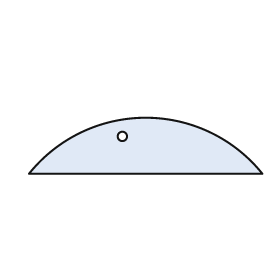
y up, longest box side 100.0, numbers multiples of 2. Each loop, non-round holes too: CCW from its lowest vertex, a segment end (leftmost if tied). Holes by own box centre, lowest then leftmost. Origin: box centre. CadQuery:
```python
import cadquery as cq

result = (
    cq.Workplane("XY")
    .moveTo(-50.0, -12.0)
    .lineTo(50.0, -12.0)
    .threePointArc((0.0, 12.0), (-50.0, -12.0))
    .close()
    .moveTo(-10.0, 4.0)
    .circle(2.0)
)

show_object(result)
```